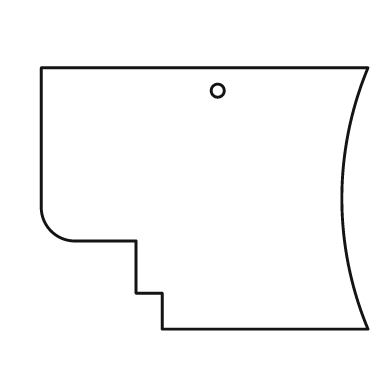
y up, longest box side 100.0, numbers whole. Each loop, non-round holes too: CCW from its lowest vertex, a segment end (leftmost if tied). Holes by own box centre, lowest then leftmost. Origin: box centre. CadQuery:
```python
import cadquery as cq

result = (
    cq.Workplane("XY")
    .moveTo(-13.0, -40.0)
    .lineTo(50.0, -40.0)
    .threePointArc((42.0, 0.0), (50.0, 40.0))
    .lineTo(-50.0, 40.0)
    .lineTo(-50.0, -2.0)
    .threePointArc((-47.0, -10.0), (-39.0, -13.0))
    .lineTo(-21.0, -13.0)
    .lineTo(-21.0, -29.0)
    .lineTo(-13.0, -29.0)
    .close()
    .moveTo(4.0, 33.0)
    .circle(2.0)
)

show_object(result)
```